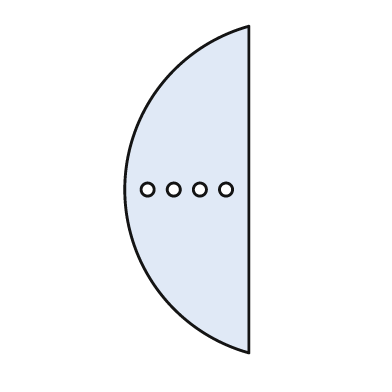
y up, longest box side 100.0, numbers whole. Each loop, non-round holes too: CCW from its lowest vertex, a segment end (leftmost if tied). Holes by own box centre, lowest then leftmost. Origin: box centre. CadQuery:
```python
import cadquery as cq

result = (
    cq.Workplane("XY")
    .moveTo(19.0, -50.0)
    .lineTo(19.0, 50.0)
    .threePointArc((-19.0, 0.0), (19.0, -50.0))
    .close()
    .moveTo(-12.0, 0.0)
    .circle(2.0)
    .moveTo(-4.0, 0.0)
    .circle(2.0)
    .moveTo(4.0, 0.0)
    .circle(2.0)
    .moveTo(12.0, 0.0)
    .circle(2.0)
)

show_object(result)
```